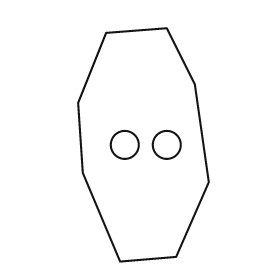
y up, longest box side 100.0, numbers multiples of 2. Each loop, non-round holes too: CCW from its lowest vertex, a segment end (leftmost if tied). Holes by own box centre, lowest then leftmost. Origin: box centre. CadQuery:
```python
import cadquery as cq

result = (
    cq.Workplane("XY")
    .moveTo(-10.0, -50.0)
    .lineTo(14.0, -48.0)
    .lineTo(28.0, -16.0)
    .lineTo(22.0, 26.0)
    .lineTo(10.0, 50.0)
    .lineTo(-16.0, 48.0)
    .lineTo(-28.0, 18.0)
    .lineTo(-26.0, -12.0)
    .close()
    .moveTo(-8.0, 0.0)
    .circle(6.0)
    .moveTo(10.0, 0.0)
    .circle(6.0)
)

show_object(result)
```